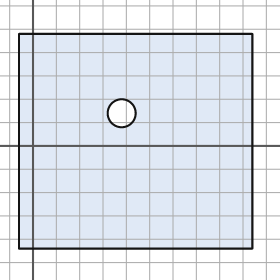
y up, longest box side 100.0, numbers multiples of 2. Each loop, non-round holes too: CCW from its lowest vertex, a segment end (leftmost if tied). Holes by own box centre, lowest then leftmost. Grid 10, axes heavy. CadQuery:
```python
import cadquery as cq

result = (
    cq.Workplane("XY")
    .moveTo(-6.0, -44.0)
    .lineTo(94.0, -44.0)
    .lineTo(94.0, 48.0)
    .lineTo(-6.0, 48.0)
    .close()
    .moveTo(38.0, 14.0)
    .circle(6.0)
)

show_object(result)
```